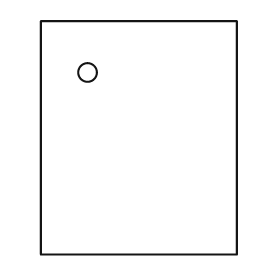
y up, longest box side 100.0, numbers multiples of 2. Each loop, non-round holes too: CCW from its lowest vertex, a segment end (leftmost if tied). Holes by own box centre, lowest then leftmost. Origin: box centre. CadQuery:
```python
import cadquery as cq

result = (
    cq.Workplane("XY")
    .moveTo(-42.0, -50.0)
    .lineTo(42.0, -50.0)
    .lineTo(42.0, 50.0)
    .lineTo(-42.0, 50.0)
    .close()
    .moveTo(-22.0, 28.0)
    .circle(4.0)
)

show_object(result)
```